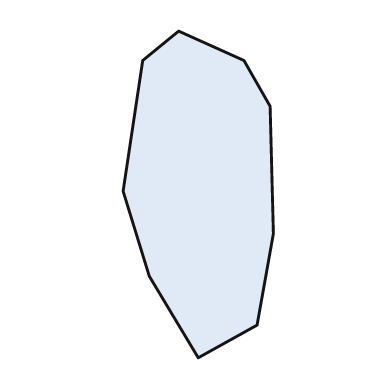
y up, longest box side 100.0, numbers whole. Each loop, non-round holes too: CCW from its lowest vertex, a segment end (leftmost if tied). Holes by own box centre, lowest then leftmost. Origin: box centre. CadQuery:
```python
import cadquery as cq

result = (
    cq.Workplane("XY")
    .moveTo(0.0, -50.0)
    .lineTo(18.0, -40.0)
    .lineTo(23.0, -12.0)
    .lineTo(22.0, 27.0)
    .lineTo(14.0, 41.0)
    .lineTo(-6.0, 50.0)
    .lineTo(-17.0, 41.0)
    .lineTo(-23.0, 1.0)
    .lineTo(-15.0, -25.0)
    .close()
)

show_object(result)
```